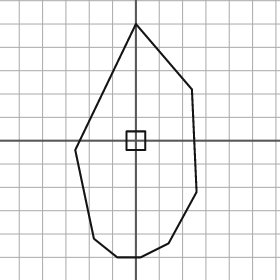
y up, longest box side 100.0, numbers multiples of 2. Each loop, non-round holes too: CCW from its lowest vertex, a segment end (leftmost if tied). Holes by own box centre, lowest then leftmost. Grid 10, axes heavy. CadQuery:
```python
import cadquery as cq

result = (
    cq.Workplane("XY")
    .moveTo(-8.0, -50.0)
    .lineTo(2.0, -50.0)
    .lineTo(14.0, -44.0)
    .lineTo(26.0, -22.0)
    .lineTo(24.0, 22.0)
    .lineTo(0.0, 50.0)
    .lineTo(-26.0, -4.0)
    .lineTo(-18.0, -42.0)
    .close()
    .moveTo(-4.0, -4.0)
    .lineTo(4.0, -4.0)
    .lineTo(4.0, 4.0)
    .lineTo(-4.0, 4.0)
    .close()
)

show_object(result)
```